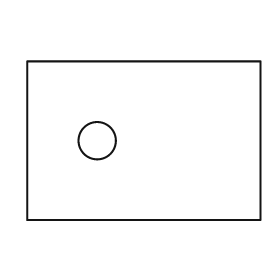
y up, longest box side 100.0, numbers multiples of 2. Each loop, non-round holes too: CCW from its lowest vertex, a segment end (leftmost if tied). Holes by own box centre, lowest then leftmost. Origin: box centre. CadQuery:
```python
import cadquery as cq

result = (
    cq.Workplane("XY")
    .moveTo(-50.0, -34.0)
    .lineTo(50.0, -34.0)
    .lineTo(50.0, 34.0)
    .lineTo(-50.0, 34.0)
    .close()
    .moveTo(-20.0, 0.0)
    .circle(8.0)
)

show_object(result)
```